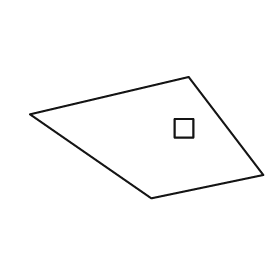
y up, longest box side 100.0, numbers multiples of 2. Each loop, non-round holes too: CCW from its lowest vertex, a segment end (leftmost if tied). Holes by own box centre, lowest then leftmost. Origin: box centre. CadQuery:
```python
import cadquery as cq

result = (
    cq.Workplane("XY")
    .moveTo(2.0, -26.0)
    .lineTo(50.0, -16.0)
    .lineTo(18.0, 26.0)
    .lineTo(-50.0, 10.0)
    .close()
    .moveTo(12.0, 0.0)
    .lineTo(20.0, 0.0)
    .lineTo(20.0, 8.0)
    .lineTo(12.0, 8.0)
    .close()
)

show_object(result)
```